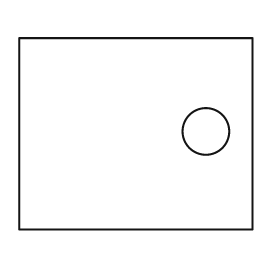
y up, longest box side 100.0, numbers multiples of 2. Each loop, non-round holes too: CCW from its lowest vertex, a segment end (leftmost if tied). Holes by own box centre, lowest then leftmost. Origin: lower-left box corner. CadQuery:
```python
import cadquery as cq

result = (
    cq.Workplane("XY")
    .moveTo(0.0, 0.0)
    .lineTo(100.0, 0.0)
    .lineTo(100.0, 82.0)
    .lineTo(0.0, 82.0)
    .close()
    .moveTo(80.0, 42.0)
    .circle(10.0)
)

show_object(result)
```